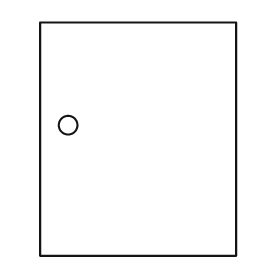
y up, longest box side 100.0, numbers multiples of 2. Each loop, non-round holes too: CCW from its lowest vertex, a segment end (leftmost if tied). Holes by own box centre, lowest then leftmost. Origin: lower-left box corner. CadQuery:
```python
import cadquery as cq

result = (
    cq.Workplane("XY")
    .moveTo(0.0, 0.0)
    .lineTo(84.0, 0.0)
    .lineTo(84.0, 100.0)
    .lineTo(0.0, 100.0)
    .close()
    .moveTo(12.0, 56.0)
    .circle(4.0)
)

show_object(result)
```